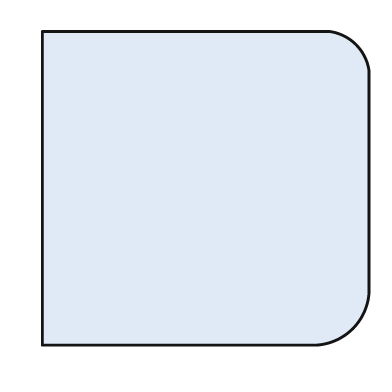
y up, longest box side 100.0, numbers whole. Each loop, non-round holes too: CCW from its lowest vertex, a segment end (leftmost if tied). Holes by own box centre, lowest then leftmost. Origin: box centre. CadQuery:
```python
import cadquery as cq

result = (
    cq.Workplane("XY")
    .moveTo(-50.0, -48.0)
    .lineTo(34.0, -48.0)
    .threePointArc((45.0, -43.0), (50.0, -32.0))
    .lineTo(50.0, 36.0)
    .threePointArc((46.0, 44.0), (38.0, 48.0))
    .lineTo(-50.0, 48.0)
    .close()
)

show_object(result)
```